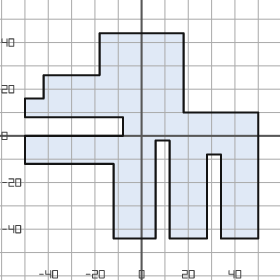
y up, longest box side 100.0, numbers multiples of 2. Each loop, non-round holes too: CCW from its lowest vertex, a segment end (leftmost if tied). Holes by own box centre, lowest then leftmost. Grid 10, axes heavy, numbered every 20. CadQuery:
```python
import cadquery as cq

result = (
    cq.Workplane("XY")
    .moveTo(-12.0, -44.0)
    .lineTo(6.0, -44.0)
    .lineTo(6.0, -2.0)
    .lineTo(12.0, -2.0)
    .lineTo(12.0, -44.0)
    .lineTo(28.0, -44.0)
    .lineTo(28.0, -8.0)
    .lineTo(34.0, -8.0)
    .lineTo(34.0, -44.0)
    .lineTo(50.0, -44.0)
    .lineTo(50.0, 10.0)
    .lineTo(18.0, 10.0)
    .lineTo(18.0, 44.0)
    .lineTo(-18.0, 44.0)
    .lineTo(-18.0, 26.0)
    .lineTo(-42.0, 26.0)
    .lineTo(-42.0, 16.0)
    .lineTo(-50.0, 16.0)
    .lineTo(-50.0, 8.0)
    .lineTo(-8.0, 8.0)
    .lineTo(-8.0, 0.0)
    .lineTo(-50.0, 0.0)
    .lineTo(-50.0, -12.0)
    .lineTo(-12.0, -12.0)
    .close()
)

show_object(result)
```